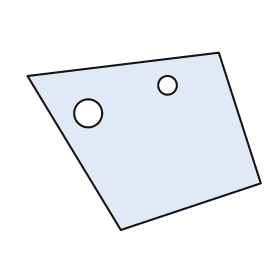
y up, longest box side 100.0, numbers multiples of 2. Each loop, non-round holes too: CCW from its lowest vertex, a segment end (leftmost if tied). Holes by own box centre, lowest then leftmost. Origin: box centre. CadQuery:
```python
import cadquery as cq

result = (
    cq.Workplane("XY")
    .moveTo(-10.0, -38.0)
    .lineTo(50.0, -18.0)
    .lineTo(32.0, 38.0)
    .lineTo(-50.0, 28.0)
    .close()
    .moveTo(-24.0, 12.0)
    .circle(6.0)
    .moveTo(10.0, 24.0)
    .circle(4.0)
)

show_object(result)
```